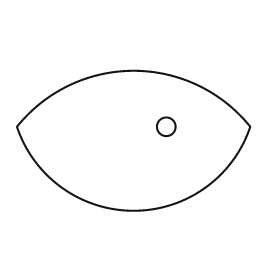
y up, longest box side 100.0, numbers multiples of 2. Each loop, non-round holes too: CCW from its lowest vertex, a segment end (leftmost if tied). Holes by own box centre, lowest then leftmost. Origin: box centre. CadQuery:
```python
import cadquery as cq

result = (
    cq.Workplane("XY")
    .moveTo(-50.0, 6.0)
    .threePointArc((0.0, -30.0), (50.0, 6.0))
    .threePointArc((0.0, 30.0), (-50.0, 6.0))
    .close()
    .moveTo(14.0, 6.0)
    .circle(4.0)
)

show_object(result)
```